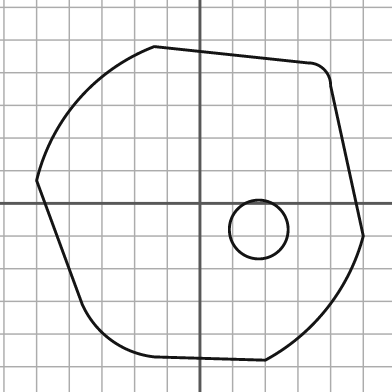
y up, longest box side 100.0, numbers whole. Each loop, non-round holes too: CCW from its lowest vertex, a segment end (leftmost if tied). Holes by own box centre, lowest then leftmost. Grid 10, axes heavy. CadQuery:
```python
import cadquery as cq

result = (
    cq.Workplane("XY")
    .moveTo(20.0, -48.0)
    .threePointArc((39.0, -32.0), (50.0, -10.0))
    .lineTo(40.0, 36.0)
    .threePointArc((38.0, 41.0), (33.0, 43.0))
    .lineTo(-14.0, 48.0)
    .threePointArc((-37.0, 32.0), (-50.0, 7.0))
    .lineTo(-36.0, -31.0)
    .threePointArc((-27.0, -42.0), (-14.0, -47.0))
    .close()
    .moveTo(18.0, -8.0)
    .circle(9.0)
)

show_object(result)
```